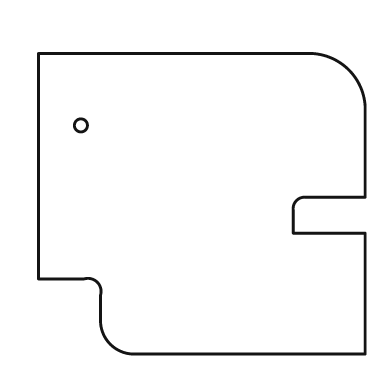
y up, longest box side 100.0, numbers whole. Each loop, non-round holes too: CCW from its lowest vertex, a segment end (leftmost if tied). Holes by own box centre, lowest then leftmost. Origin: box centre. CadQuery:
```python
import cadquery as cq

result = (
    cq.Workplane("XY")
    .moveTo(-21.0, -46.0)
    .lineTo(50.0, -46.0)
    .lineTo(50.0, -9.0)
    .lineTo(28.0, -9.0)
    .lineTo(28.0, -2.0)
    .threePointArc((29.0, 1.0), (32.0, 2.0))
    .lineTo(50.0, 2.0)
    .lineTo(50.0, 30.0)
    .threePointArc((45.0, 41.0), (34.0, 46.0))
    .lineTo(-50.0, 46.0)
    .lineTo(-50.0, -23.0)
    .lineTo(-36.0, -23.0)
    .threePointArc((-32.0, -24.0), (-31.0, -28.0))
    .lineTo(-31.0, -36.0)
    .threePointArc((-28.0, -43.0), (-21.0, -46.0))
    .close()
    .moveTo(-37.0, 24.0)
    .circle(2.0)
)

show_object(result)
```